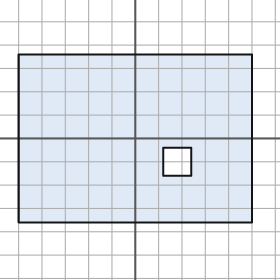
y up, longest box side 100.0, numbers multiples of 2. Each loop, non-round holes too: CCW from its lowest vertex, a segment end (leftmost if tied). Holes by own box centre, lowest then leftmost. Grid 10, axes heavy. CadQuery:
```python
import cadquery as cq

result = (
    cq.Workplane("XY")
    .moveTo(-50.0, -36.0)
    .lineTo(50.0, -36.0)
    .lineTo(50.0, 36.0)
    .lineTo(-50.0, 36.0)
    .close()
    .moveTo(12.0, -16.0)
    .lineTo(24.0, -16.0)
    .lineTo(24.0, -4.0)
    .lineTo(12.0, -4.0)
    .close()
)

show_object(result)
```